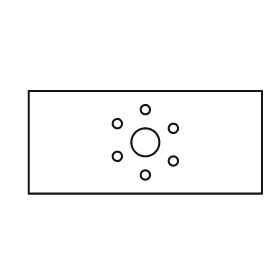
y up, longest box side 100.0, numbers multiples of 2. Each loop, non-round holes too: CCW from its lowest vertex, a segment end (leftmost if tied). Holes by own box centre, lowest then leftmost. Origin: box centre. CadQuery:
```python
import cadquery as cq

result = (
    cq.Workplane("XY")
    .moveTo(-50.0, -22.0)
    .lineTo(50.0, -22.0)
    .lineTo(50.0, 22.0)
    .lineTo(-50.0, 22.0)
    .close()
    .moveTo(0.0, -14.0)
    .circle(2.0)
    .moveTo(12.0, -8.0)
    .circle(2.0)
    .moveTo(-12.0, -6.0)
    .circle(2.0)
    .moveTo(0.0, 0.0)
    .circle(6.0)
    .moveTo(12.0, 6.0)
    .circle(2.0)
    .moveTo(-12.0, 8.0)
    .circle(2.0)
    .moveTo(0.0, 14.0)
    .circle(2.0)
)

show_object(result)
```